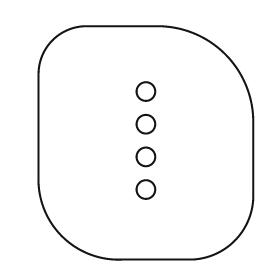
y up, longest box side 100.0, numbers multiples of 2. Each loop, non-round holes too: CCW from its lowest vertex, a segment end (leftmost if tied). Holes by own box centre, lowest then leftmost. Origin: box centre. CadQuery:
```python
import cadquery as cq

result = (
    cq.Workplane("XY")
    .moveTo(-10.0, -50.0)
    .lineTo(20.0, -50.0)
    .threePointArc((38.0, -42.0), (46.0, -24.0))
    .lineTo(46.0, 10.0)
    .threePointArc((34.0, 38.0), (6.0, 50.0))
    .lineTo(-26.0, 50.0)
    .threePointArc((-40.0, 44.0), (-46.0, 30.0))
    .lineTo(-46.0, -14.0)
    .threePointArc((-36.0, -40.0), (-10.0, -50.0))
    .close()
    .moveTo(0.0, -20.0)
    .circle(4.0)
    .moveTo(0.0, -6.0)
    .circle(4.0)
    .moveTo(0.0, 8.0)
    .circle(4.0)
    .moveTo(0.0, 22.0)
    .circle(4.0)
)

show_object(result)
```